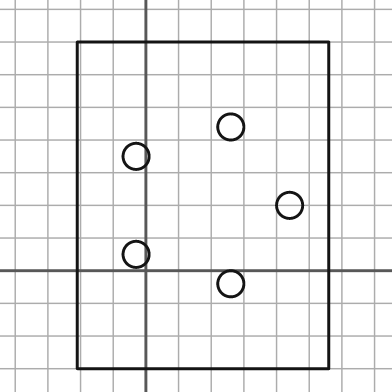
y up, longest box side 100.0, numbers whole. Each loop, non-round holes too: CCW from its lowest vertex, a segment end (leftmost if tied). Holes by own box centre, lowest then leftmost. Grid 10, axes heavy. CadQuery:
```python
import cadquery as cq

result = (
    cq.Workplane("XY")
    .moveTo(-21.0, -30.0)
    .lineTo(56.0, -30.0)
    .lineTo(56.0, 70.0)
    .lineTo(-21.0, 70.0)
    .close()
    .moveTo(26.0, -4.0)
    .circle(4.0)
    .moveTo(-3.0, 5.0)
    .circle(4.0)
    .moveTo(44.0, 20.0)
    .circle(4.0)
    .moveTo(-3.0, 35.0)
    .circle(4.0)
    .moveTo(26.0, 44.0)
    .circle(4.0)
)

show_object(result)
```